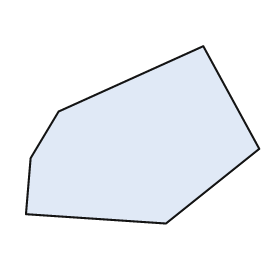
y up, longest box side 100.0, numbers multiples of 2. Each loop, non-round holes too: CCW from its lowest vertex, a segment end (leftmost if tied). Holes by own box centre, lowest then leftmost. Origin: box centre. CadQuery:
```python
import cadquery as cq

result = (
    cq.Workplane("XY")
    .moveTo(10.0, -38.0)
    .lineTo(50.0, -6.0)
    .lineTo(26.0, 38.0)
    .lineTo(-36.0, 10.0)
    .lineTo(-48.0, -10.0)
    .lineTo(-50.0, -34.0)
    .close()
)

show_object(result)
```